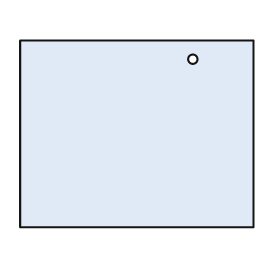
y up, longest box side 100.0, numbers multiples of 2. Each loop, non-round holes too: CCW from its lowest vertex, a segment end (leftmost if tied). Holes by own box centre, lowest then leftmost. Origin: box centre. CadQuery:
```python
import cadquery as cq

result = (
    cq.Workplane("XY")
    .moveTo(-50.0, -40.0)
    .lineTo(50.0, -40.0)
    .lineTo(50.0, 40.0)
    .lineTo(-50.0, 40.0)
    .close()
    .moveTo(24.0, 32.0)
    .circle(2.0)
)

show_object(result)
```